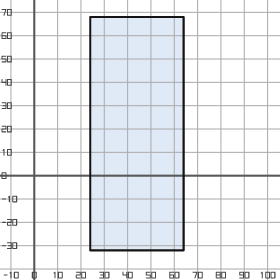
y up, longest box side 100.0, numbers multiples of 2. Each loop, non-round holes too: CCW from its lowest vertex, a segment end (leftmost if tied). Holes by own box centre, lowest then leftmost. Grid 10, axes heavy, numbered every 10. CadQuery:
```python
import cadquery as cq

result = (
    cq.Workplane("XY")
    .moveTo(24.0, -32.0)
    .lineTo(64.0, -32.0)
    .lineTo(64.0, 68.0)
    .lineTo(24.0, 68.0)
    .close()
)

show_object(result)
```